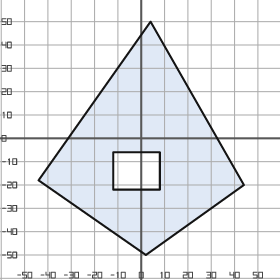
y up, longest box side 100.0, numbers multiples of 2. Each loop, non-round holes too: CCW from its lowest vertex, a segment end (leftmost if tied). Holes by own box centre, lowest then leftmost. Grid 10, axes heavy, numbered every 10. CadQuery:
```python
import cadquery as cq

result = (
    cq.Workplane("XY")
    .moveTo(2.0, -50.0)
    .lineTo(44.0, -20.0)
    .lineTo(4.0, 50.0)
    .lineTo(-44.0, -18.0)
    .close()
    .moveTo(-12.0, -22.0)
    .lineTo(8.0, -22.0)
    .lineTo(8.0, -6.0)
    .lineTo(-12.0, -6.0)
    .close()
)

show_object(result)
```